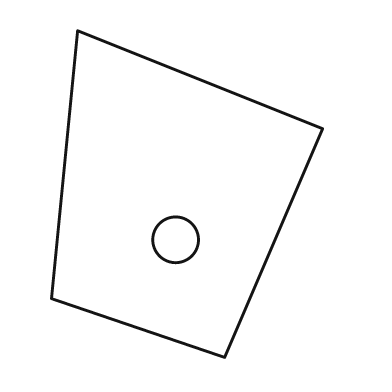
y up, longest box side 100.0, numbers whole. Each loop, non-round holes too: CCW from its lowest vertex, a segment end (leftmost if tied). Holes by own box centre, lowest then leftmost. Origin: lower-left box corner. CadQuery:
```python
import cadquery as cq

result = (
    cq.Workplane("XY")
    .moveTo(53.0, 0.0)
    .lineTo(83.0, 70.0)
    .lineTo(8.0, 100.0)
    .lineTo(0.0, 18.0)
    .close()
    .moveTo(38.0, 36.0)
    .circle(7.0)
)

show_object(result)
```